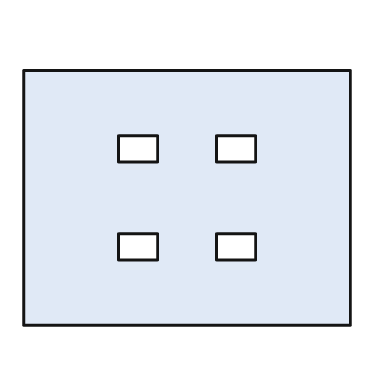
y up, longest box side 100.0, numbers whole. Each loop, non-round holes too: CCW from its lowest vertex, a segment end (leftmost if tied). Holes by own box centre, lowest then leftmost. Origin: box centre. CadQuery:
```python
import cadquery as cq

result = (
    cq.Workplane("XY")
    .moveTo(-50.0, -39.0)
    .lineTo(50.0, -39.0)
    .lineTo(50.0, 39.0)
    .lineTo(-50.0, 39.0)
    .close()
    .moveTo(-21.0, -19.0)
    .lineTo(-9.0, -19.0)
    .lineTo(-9.0, -11.0)
    .lineTo(-21.0, -11.0)
    .close()
    .moveTo(9.0, -19.0)
    .lineTo(21.0, -19.0)
    .lineTo(21.0, -11.0)
    .lineTo(9.0, -11.0)
    .close()
    .moveTo(-21.0, 11.0)
    .lineTo(-9.0, 11.0)
    .lineTo(-9.0, 19.0)
    .lineTo(-21.0, 19.0)
    .close()
    .moveTo(9.0, 11.0)
    .lineTo(21.0, 11.0)
    .lineTo(21.0, 19.0)
    .lineTo(9.0, 19.0)
    .close()
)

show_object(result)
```